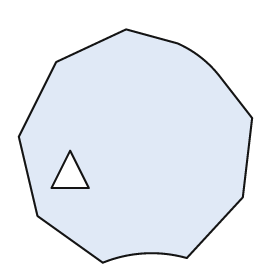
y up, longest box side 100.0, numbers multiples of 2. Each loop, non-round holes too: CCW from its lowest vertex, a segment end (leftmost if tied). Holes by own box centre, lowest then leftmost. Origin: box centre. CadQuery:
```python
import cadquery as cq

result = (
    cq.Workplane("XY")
    .moveTo(-14.0, -50.0)
    .threePointArc((4.0, -46.0), (22.0, -48.0))
    .lineTo(46.0, -22.0)
    .lineTo(50.0, 12.0)
    .lineTo(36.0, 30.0)
    .threePointArc((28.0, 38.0), (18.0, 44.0))
    .lineTo(-4.0, 50.0)
    .lineTo(-34.0, 36.0)
    .lineTo(-50.0, 4.0)
    .lineTo(-42.0, -30.0)
    .close()
    .moveTo(-36.0, -18.0)
    .lineTo(-20.0, -18.0)
    .lineTo(-28.0, -2.0)
    .close()
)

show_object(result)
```